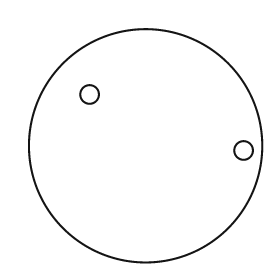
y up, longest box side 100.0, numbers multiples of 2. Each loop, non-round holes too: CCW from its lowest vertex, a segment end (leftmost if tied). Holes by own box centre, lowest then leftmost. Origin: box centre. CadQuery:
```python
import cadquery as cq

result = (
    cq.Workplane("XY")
    .moveTo(0.0, 0.0)
    .circle(50.0)
    .moveTo(42.0, -2.0)
    .circle(4.0)
    .moveTo(-24.0, 22.0)
    .circle(4.0)
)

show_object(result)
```